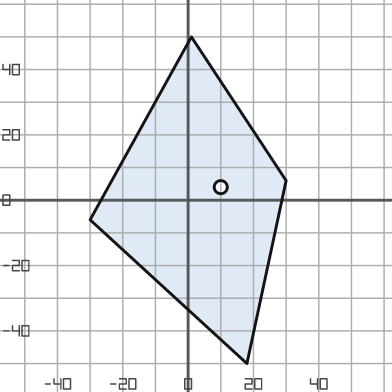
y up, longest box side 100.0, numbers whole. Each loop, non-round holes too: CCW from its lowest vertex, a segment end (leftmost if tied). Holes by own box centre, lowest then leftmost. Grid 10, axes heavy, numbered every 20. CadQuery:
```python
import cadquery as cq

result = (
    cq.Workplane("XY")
    .moveTo(18.0, -50.0)
    .lineTo(30.0, 6.0)
    .lineTo(1.0, 50.0)
    .lineTo(-30.0, -6.0)
    .close()
    .moveTo(10.0, 4.0)
    .circle(2.0)
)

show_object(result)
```